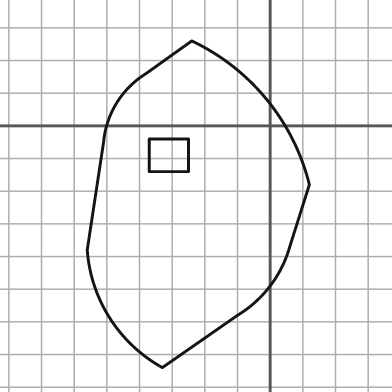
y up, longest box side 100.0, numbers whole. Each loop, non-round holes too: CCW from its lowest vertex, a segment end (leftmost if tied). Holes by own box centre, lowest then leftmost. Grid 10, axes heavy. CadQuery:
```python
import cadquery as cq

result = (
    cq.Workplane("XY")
    .moveTo(-33.0, -74.0)
    .lineTo(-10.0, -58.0)
    .threePointArc((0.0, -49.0), (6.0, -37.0))
    .lineTo(12.0, -18.0)
    .threePointArc((-1.0, 8.0), (-24.0, 26.0))
    .lineTo(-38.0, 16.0)
    .threePointArc((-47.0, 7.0), (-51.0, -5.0))
    .lineTo(-56.0, -38.0)
    .threePointArc((-49.0, -59.0), (-33.0, -74.0))
    .close()
    .moveTo(-37.0, -14.0)
    .lineTo(-25.0, -14.0)
    .lineTo(-25.0, -4.0)
    .lineTo(-37.0, -4.0)
    .close()
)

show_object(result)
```